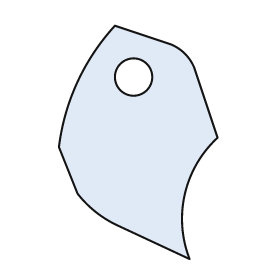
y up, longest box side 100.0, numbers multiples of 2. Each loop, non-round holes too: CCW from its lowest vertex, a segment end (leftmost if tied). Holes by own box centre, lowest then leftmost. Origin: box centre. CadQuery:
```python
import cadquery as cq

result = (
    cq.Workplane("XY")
    .moveTo(22.0, -50.0)
    .threePointArc((20.0, -22.0), (34.0, 2.0))
    .lineTo(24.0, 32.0)
    .threePointArc((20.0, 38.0), (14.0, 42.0))
    .lineTo(-10.0, 50.0)
    .threePointArc((-26.0, 26.0), (-34.0, -2.0))
    .lineTo(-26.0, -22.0)
    .threePointArc((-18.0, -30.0), (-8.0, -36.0))
    .close()
    .moveTo(-2.0, 28.0)
    .circle(8.0)
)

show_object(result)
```